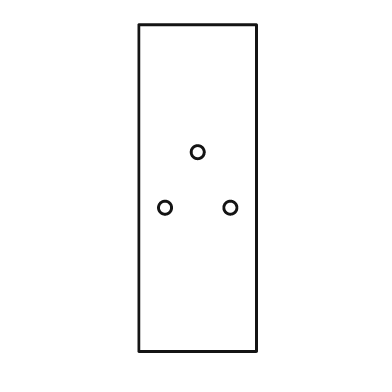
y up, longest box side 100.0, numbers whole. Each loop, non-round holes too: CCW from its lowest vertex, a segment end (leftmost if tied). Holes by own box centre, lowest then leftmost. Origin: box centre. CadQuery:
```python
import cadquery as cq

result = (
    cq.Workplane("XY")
    .moveTo(-18.0, -50.0)
    .lineTo(18.0, -50.0)
    .lineTo(18.0, 50.0)
    .lineTo(-18.0, 50.0)
    .close()
    .moveTo(-10.0, -6.0)
    .circle(2.0)
    .moveTo(10.0, -6.0)
    .circle(2.0)
    .moveTo(0.0, 11.0)
    .circle(2.0)
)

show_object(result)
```